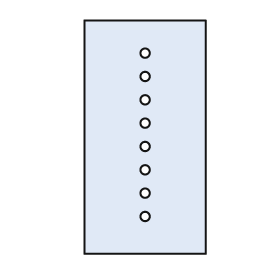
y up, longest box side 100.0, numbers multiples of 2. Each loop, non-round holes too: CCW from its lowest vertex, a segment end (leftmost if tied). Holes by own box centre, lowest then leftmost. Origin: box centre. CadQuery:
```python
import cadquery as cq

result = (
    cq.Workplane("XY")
    .moveTo(-26.0, -50.0)
    .lineTo(26.0, -50.0)
    .lineTo(26.0, 50.0)
    .lineTo(-26.0, 50.0)
    .close()
    .moveTo(0.0, -34.0)
    .circle(2.0)
    .moveTo(0.0, -24.0)
    .circle(2.0)
    .moveTo(0.0, -14.0)
    .circle(2.0)
    .moveTo(0.0, -4.0)
    .circle(2.0)
    .moveTo(0.0, 6.0)
    .circle(2.0)
    .moveTo(0.0, 16.0)
    .circle(2.0)
    .moveTo(0.0, 26.0)
    .circle(2.0)
    .moveTo(0.0, 36.0)
    .circle(2.0)
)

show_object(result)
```